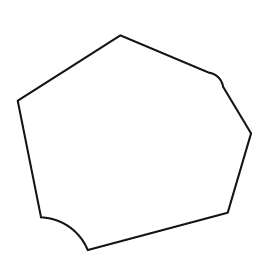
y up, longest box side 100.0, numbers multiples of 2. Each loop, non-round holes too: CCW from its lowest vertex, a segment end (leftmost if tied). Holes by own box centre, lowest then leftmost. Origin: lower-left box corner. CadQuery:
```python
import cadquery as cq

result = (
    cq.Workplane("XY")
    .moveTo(30.0, 0.0)
    .lineTo(90.0, 16.0)
    .lineTo(100.0, 50.0)
    .lineTo(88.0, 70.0)
    .threePointArc((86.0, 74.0), (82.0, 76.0))
    .lineTo(44.0, 92.0)
    .lineTo(0.0, 64.0)
    .lineTo(10.0, 14.0)
    .threePointArc((22.0, 10.0), (30.0, 0.0))
    .close()
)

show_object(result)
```